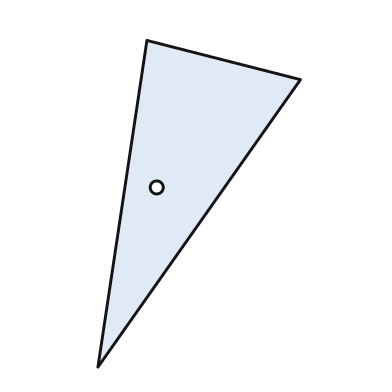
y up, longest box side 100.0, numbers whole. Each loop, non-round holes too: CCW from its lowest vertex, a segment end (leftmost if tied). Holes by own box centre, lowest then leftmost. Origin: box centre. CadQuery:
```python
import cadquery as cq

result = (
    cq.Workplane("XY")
    .moveTo(-31.0, -50.0)
    .lineTo(31.0, 38.0)
    .lineTo(-16.0, 50.0)
    .close()
    .moveTo(-13.0, 5.0)
    .circle(2.0)
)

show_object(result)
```